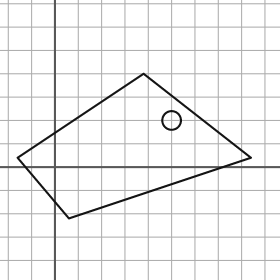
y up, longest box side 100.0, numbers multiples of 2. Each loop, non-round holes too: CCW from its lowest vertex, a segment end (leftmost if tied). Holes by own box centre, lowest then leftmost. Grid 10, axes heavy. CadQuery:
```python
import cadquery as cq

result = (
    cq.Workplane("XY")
    .moveTo(6.0, -22.0)
    .lineTo(84.0, 4.0)
    .lineTo(38.0, 40.0)
    .lineTo(-16.0, 4.0)
    .close()
    .moveTo(50.0, 20.0)
    .circle(4.0)
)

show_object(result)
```